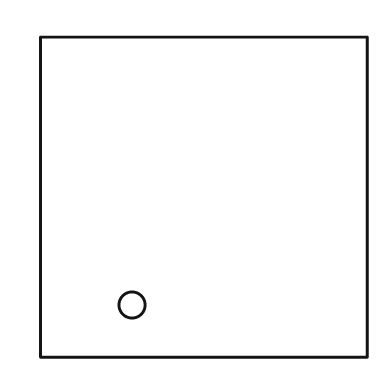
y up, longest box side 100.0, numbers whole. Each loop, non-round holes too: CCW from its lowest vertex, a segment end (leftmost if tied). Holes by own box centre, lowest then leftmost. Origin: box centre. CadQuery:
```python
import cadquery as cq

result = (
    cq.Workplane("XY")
    .moveTo(-50.0, -49.0)
    .lineTo(50.0, -49.0)
    .lineTo(50.0, 49.0)
    .lineTo(-50.0, 49.0)
    .close()
    .moveTo(-22.0, -33.0)
    .circle(4.0)
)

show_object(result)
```